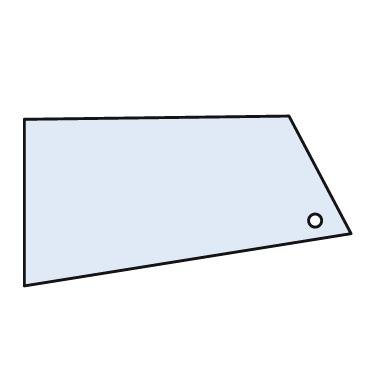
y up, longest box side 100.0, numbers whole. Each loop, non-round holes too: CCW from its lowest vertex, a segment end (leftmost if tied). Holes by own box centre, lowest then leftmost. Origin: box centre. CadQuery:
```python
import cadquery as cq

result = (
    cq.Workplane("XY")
    .moveTo(-50.0, -26.0)
    .lineTo(50.0, -10.0)
    .lineTo(31.0, 26.0)
    .lineTo(-50.0, 25.0)
    .close()
    .moveTo(39.0, -6.0)
    .circle(2.0)
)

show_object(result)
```